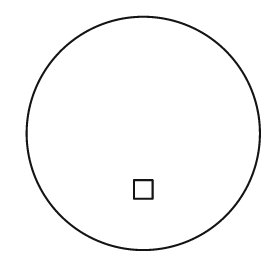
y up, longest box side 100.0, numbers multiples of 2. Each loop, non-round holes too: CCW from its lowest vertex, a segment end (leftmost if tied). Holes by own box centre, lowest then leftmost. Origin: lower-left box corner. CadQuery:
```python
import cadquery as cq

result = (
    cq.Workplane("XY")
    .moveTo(50.0, 50.0)
    .circle(50.0)
    .moveTo(46.0, 22.0)
    .lineTo(54.0, 22.0)
    .lineTo(54.0, 30.0)
    .lineTo(46.0, 30.0)
    .close()
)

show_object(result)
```